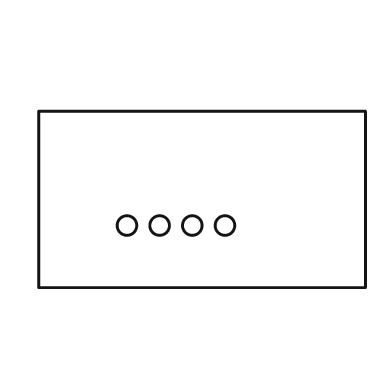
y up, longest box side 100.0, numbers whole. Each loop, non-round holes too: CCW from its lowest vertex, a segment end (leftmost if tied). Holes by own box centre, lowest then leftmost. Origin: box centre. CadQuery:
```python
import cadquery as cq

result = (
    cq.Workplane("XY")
    .moveTo(-50.0, -27.0)
    .lineTo(50.0, -27.0)
    .lineTo(50.0, 27.0)
    .lineTo(-50.0, 27.0)
    .close()
    .moveTo(-23.0, -8.0)
    .circle(3.0)
    .moveTo(-13.0, -8.0)
    .circle(3.0)
    .moveTo(-3.0, -8.0)
    .circle(3.0)
    .moveTo(7.0, -8.0)
    .circle(3.0)
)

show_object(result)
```